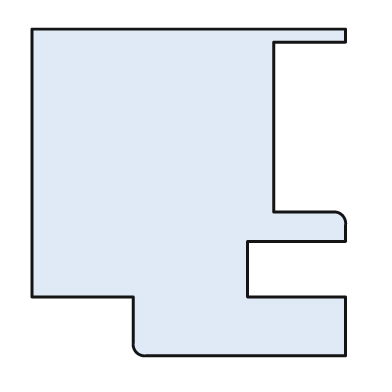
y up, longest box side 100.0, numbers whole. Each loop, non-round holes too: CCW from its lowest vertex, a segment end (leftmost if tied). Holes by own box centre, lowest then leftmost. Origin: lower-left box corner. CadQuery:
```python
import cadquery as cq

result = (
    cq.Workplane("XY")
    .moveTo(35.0, 0.0)
    .lineTo(96.0, 0.0)
    .lineTo(96.0, 18.0)
    .lineTo(66.0, 18.0)
    .lineTo(66.0, 35.0)
    .lineTo(96.0, 35.0)
    .lineTo(96.0, 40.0)
    .threePointArc((95.0, 43.0), (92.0, 44.0))
    .lineTo(74.0, 44.0)
    .lineTo(74.0, 96.0)
    .lineTo(96.0, 96.0)
    .lineTo(96.0, 100.0)
    .lineTo(0.0, 100.0)
    .lineTo(0.0, 18.0)
    .lineTo(31.0, 18.0)
    .lineTo(31.0, 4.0)
    .threePointArc((32.0, 1.0), (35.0, 0.0))
    .close()
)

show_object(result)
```